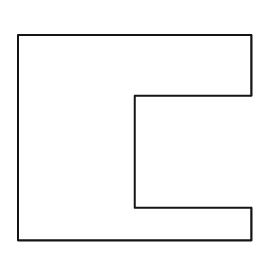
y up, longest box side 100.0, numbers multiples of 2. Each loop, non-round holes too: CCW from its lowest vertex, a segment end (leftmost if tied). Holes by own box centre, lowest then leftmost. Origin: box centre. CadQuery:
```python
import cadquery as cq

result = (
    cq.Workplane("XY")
    .moveTo(-50.0, -44.0)
    .lineTo(50.0, -44.0)
    .lineTo(50.0, -30.0)
    .lineTo(0.0, -30.0)
    .lineTo(0.0, 18.0)
    .lineTo(50.0, 18.0)
    .lineTo(50.0, 44.0)
    .lineTo(-50.0, 44.0)
    .close()
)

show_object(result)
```